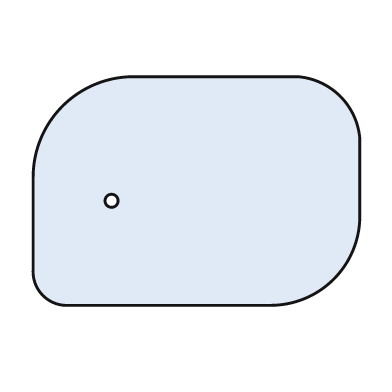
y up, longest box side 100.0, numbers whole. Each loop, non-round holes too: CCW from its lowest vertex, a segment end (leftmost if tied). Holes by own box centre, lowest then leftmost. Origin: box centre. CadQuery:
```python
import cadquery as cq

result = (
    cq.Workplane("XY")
    .moveTo(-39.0, -35.0)
    .lineTo(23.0, -35.0)
    .threePointArc((42.0, -27.0), (50.0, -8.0))
    .lineTo(50.0, 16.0)
    .threePointArc((44.0, 29.0), (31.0, 35.0))
    .lineTo(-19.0, 35.0)
    .threePointArc((-41.0, 26.0), (-50.0, 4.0))
    .lineTo(-50.0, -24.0)
    .threePointArc((-47.0, -32.0), (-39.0, -35.0))
    .close()
    .moveTo(-26.0, -3.0)
    .circle(2.0)
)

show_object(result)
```